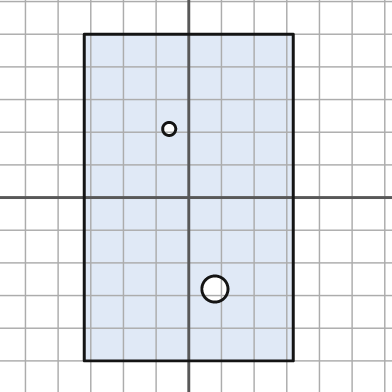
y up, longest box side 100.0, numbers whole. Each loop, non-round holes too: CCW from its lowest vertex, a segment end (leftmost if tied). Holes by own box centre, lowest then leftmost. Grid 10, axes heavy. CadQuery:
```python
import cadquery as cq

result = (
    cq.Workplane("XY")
    .moveTo(-32.0, -50.0)
    .lineTo(32.0, -50.0)
    .lineTo(32.0, 50.0)
    .lineTo(-32.0, 50.0)
    .close()
    .moveTo(8.0, -28.0)
    .circle(4.0)
    .moveTo(-6.0, 21.0)
    .circle(2.0)
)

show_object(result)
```